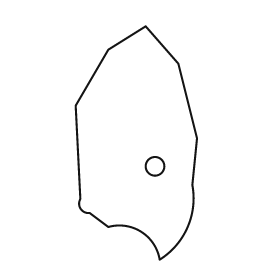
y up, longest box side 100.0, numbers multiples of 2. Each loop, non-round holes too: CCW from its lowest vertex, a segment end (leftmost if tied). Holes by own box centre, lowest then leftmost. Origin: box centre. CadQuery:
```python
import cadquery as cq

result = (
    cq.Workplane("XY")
    .moveTo(10.0, -50.0)
    .threePointArc((22.0, -36.0), (24.0, -18.0))
    .lineTo(26.0, 2.0)
    .lineTo(18.0, 34.0)
    .lineTo(4.0, 50.0)
    .lineTo(-12.0, 40.0)
    .lineTo(-26.0, 16.0)
    .lineTo(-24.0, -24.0)
    .threePointArc((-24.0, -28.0), (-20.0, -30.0))
    .lineTo(-12.0, -36.0)
    .threePointArc((2.0, -38.0), (10.0, -50.0))
    .close()
    .moveTo(8.0, -10.0)
    .circle(4.0)
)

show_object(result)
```